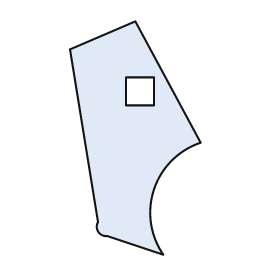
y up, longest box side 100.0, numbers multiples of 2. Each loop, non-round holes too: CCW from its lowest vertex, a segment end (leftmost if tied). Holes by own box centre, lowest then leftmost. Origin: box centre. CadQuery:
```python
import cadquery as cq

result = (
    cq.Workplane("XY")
    .moveTo(12.0, -50.0)
    .threePointArc((8.0, -22.0), (28.0, -2.0))
    .lineTo(0.0, 50.0)
    .lineTo(-28.0, 38.0)
    .lineTo(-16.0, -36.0)
    .threePointArc((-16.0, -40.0), (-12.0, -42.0))
    .close()
    .moveTo(-4.0, 14.0)
    .lineTo(8.0, 14.0)
    .lineTo(8.0, 26.0)
    .lineTo(-4.0, 26.0)
    .close()
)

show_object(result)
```